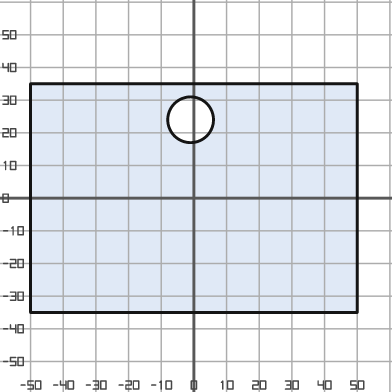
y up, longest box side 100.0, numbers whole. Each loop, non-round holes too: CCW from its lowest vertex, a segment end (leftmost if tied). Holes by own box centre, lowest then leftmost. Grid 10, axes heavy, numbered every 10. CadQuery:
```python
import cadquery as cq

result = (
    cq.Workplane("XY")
    .moveTo(-50.0, -35.0)
    .lineTo(50.0, -35.0)
    .lineTo(50.0, 35.0)
    .lineTo(-50.0, 35.0)
    .close()
    .moveTo(-1.0, 24.0)
    .circle(7.0)
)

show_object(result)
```